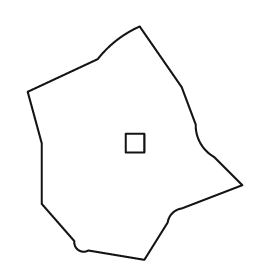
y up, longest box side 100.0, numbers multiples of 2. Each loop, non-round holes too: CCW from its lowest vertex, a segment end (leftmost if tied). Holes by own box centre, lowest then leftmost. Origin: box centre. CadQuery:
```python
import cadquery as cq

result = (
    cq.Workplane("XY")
    .moveTo(4.0, -50.0)
    .lineTo(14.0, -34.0)
    .threePointArc((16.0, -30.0), (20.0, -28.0))
    .lineTo(46.0, -18.0)
    .lineTo(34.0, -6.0)
    .threePointArc((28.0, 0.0), (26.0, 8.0))
    .lineTo(20.0, 24.0)
    .lineTo(2.0, 50.0)
    .threePointArc((-8.0, 44.0), (-16.0, 36.0))
    .lineTo(-46.0, 22.0)
    .lineTo(-40.0, 0.0)
    .lineTo(-40.0, -26.0)
    .lineTo(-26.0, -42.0)
    .threePointArc((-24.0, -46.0), (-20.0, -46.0))
    .close()
    .moveTo(-4.0, -4.0)
    .lineTo(4.0, -4.0)
    .lineTo(4.0, 4.0)
    .lineTo(-4.0, 4.0)
    .close()
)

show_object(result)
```